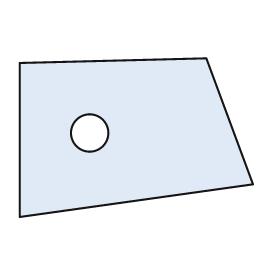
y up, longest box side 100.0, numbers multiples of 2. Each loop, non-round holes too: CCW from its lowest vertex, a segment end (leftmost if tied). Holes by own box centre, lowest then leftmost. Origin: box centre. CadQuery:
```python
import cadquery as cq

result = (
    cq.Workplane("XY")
    .moveTo(-50.0, -34.0)
    .lineTo(50.0, -20.0)
    .lineTo(30.0, 34.0)
    .lineTo(-50.0, 32.0)
    .close()
    .moveTo(-20.0, 2.0)
    .circle(8.0)
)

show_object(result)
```